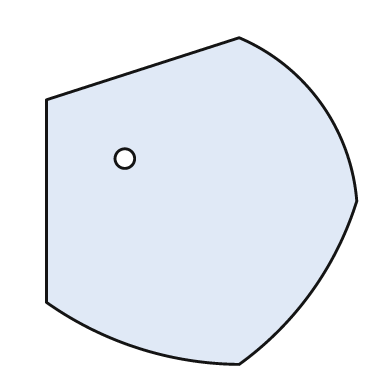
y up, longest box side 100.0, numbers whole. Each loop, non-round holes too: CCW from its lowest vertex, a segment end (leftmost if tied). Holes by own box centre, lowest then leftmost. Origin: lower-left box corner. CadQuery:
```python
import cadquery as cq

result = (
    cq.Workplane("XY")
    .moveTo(59.0, 0.0)
    .threePointArc((81.0, 22.0), (95.0, 50.0))
    .threePointArc((84.0, 80.0), (59.0, 100.0))
    .lineTo(0.0, 81.0)
    .lineTo(0.0, 19.0)
    .threePointArc((28.0, 5.0), (59.0, 0.0))
    .close()
    .moveTo(24.0, 63.0)
    .circle(3.0)
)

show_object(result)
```